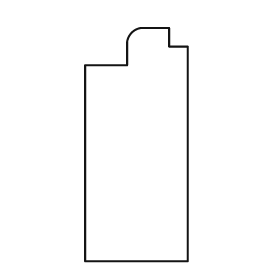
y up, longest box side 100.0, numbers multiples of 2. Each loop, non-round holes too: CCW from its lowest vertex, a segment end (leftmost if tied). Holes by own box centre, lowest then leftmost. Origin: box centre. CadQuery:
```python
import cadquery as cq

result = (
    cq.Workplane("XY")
    .moveTo(-22.0, -50.0)
    .lineTo(22.0, -50.0)
    .lineTo(22.0, 42.0)
    .lineTo(14.0, 42.0)
    .lineTo(14.0, 50.0)
    .lineTo(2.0, 50.0)
    .threePointArc((-2.0, 48.0), (-4.0, 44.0))
    .lineTo(-4.0, 34.0)
    .lineTo(-22.0, 34.0)
    .close()
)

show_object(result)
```